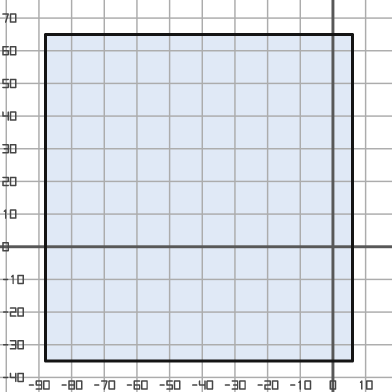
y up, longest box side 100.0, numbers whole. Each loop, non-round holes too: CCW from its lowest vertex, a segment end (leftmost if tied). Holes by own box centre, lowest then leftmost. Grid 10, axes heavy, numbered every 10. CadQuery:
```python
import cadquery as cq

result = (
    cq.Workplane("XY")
    .moveTo(-88.0, -35.0)
    .lineTo(6.0, -35.0)
    .lineTo(6.0, 65.0)
    .lineTo(-88.0, 65.0)
    .close()
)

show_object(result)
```